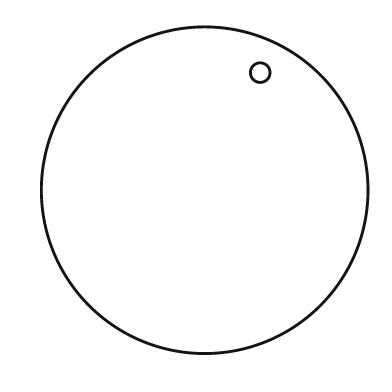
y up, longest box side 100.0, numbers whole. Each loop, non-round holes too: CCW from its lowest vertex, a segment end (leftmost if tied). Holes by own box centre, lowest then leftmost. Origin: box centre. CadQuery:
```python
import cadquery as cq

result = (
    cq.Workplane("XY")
    .moveTo(0.0, 0.0)
    .circle(50.0)
    .moveTo(17.0, 36.0)
    .circle(3.0)
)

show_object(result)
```